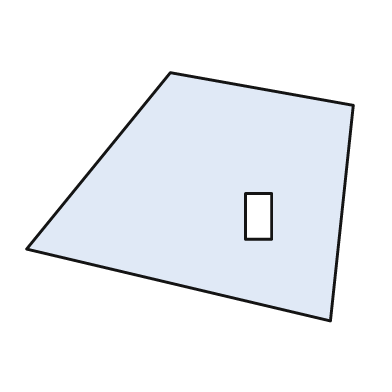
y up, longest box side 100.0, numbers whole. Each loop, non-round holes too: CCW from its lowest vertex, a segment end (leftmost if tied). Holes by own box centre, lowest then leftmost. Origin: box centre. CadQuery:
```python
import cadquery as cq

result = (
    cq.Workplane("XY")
    .moveTo(43.0, -38.0)
    .lineTo(50.0, 28.0)
    .lineTo(-6.0, 38.0)
    .lineTo(-50.0, -16.0)
    .close()
    .moveTo(17.0, -13.0)
    .lineTo(25.0, -13.0)
    .lineTo(25.0, 1.0)
    .lineTo(17.0, 1.0)
    .close()
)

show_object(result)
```